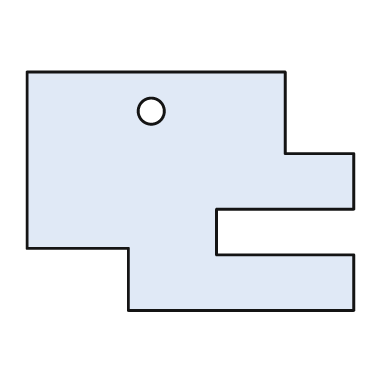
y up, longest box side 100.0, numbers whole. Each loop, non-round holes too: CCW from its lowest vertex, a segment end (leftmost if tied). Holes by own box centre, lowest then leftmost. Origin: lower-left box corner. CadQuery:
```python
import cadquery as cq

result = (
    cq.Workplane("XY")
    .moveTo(31.0, 0.0)
    .lineTo(100.0, 0.0)
    .lineTo(100.0, 17.0)
    .lineTo(58.0, 17.0)
    .lineTo(58.0, 31.0)
    .lineTo(100.0, 31.0)
    .lineTo(100.0, 48.0)
    .lineTo(79.0, 48.0)
    .lineTo(79.0, 73.0)
    .lineTo(0.0, 73.0)
    .lineTo(0.0, 19.0)
    .lineTo(31.0, 19.0)
    .close()
    .moveTo(38.0, 61.0)
    .circle(4.0)
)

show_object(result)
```